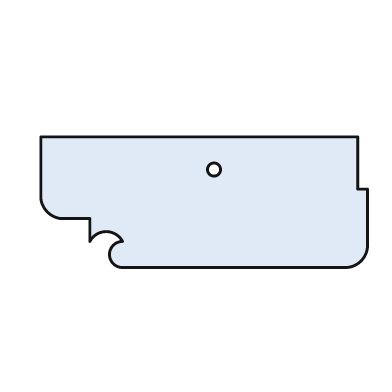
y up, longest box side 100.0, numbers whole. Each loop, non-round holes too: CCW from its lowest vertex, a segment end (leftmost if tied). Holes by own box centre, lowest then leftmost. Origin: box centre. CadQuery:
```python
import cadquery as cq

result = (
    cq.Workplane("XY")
    .moveTo(-25.0, -20.0)
    .lineTo(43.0, -20.0)
    .threePointArc((48.0, -18.0), (50.0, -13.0))
    .lineTo(50.0, 4.0)
    .lineTo(47.0, 4.0)
    .lineTo(47.0, 20.0)
    .lineTo(-50.0, 20.0)
    .lineTo(-50.0, 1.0)
    .threePointArc((-48.0, -3.0), (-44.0, -5.0))
    .lineTo(-35.0, -5.0)
    .lineTo(-35.0, -12.0)
    .threePointArc((-30.0, -9.0), (-25.0, -12.0))
    .threePointArc((-29.0, -16.0), (-25.0, -20.0))
    .close()
    .moveTo(3.0, 10.0)
    .circle(2.0)
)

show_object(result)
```